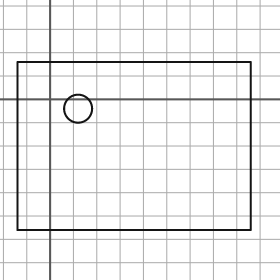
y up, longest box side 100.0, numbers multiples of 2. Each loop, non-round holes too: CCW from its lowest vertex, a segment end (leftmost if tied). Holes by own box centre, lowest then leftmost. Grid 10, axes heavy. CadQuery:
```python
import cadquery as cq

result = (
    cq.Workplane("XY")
    .moveTo(-14.0, -56.0)
    .lineTo(86.0, -56.0)
    .lineTo(86.0, 16.0)
    .lineTo(-14.0, 16.0)
    .close()
    .moveTo(12.0, -4.0)
    .circle(6.0)
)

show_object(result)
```